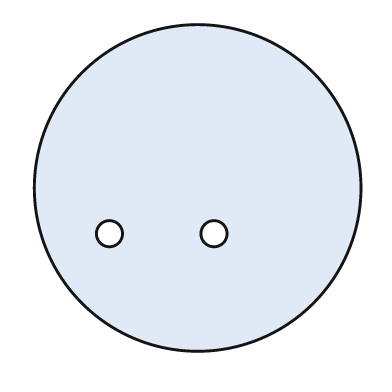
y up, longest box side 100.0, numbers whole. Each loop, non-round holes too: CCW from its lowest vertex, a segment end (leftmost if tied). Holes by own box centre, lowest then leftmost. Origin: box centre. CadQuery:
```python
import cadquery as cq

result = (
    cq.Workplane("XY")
    .moveTo(0.0, 0.0)
    .circle(50.0)
    .moveTo(-27.0, -14.0)
    .circle(4.0)
    .moveTo(5.0, -14.0)
    .circle(4.0)
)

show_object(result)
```